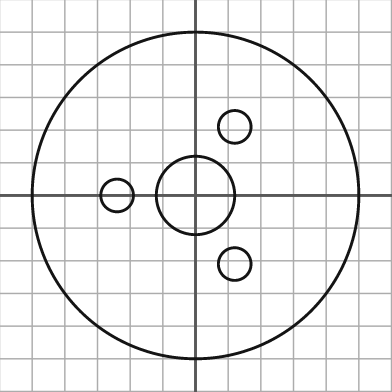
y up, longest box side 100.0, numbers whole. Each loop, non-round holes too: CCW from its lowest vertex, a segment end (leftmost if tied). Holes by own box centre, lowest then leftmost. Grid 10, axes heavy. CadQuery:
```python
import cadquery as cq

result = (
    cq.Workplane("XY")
    .moveTo(0.0, 0.0)
    .circle(50.0)
    .moveTo(12.0, -21.0)
    .circle(5.0)
    .moveTo(-24.0, 0.0)
    .circle(5.0)
    .moveTo(0.0, 0.0)
    .circle(12.0)
    .moveTo(12.0, 21.0)
    .circle(5.0)
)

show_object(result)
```